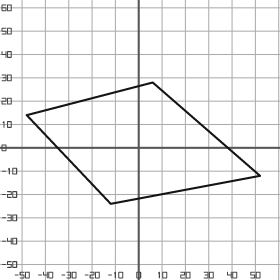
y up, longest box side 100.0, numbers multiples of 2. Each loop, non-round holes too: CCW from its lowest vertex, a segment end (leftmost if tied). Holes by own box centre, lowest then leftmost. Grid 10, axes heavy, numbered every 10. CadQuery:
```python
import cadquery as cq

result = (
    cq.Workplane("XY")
    .moveTo(-12.0, -24.0)
    .lineTo(52.0, -12.0)
    .lineTo(6.0, 28.0)
    .lineTo(-48.0, 14.0)
    .close()
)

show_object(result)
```